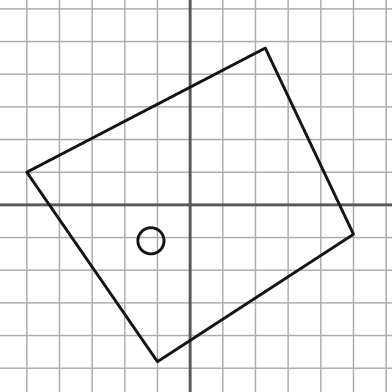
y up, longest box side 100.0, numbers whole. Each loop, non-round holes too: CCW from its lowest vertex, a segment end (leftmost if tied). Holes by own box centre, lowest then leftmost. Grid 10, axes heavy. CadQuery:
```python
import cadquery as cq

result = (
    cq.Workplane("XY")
    .moveTo(-10.0, -48.0)
    .lineTo(50.0, -9.0)
    .lineTo(23.0, 48.0)
    .lineTo(-50.0, 10.0)
    .close()
    .moveTo(-12.0, -11.0)
    .circle(4.0)
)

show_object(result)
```